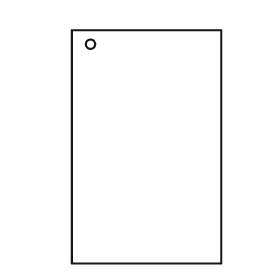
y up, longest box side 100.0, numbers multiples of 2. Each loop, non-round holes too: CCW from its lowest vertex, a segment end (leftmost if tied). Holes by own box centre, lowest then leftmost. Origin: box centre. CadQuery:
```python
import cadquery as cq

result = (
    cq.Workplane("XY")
    .moveTo(-32.0, -50.0)
    .lineTo(32.0, -50.0)
    .lineTo(32.0, 50.0)
    .lineTo(-32.0, 50.0)
    .close()
    .moveTo(-24.0, 44.0)
    .circle(2.0)
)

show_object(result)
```